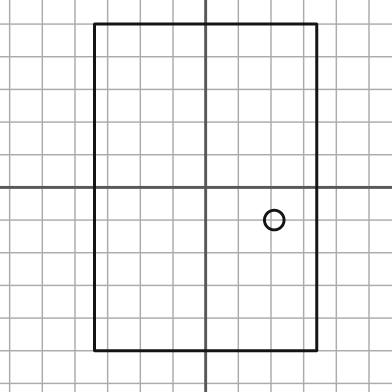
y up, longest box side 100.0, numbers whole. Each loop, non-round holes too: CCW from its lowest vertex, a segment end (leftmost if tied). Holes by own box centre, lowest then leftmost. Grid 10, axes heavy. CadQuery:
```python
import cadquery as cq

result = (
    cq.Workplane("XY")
    .moveTo(-34.0, -50.0)
    .lineTo(34.0, -50.0)
    .lineTo(34.0, 50.0)
    .lineTo(-34.0, 50.0)
    .close()
    .moveTo(21.0, -10.0)
    .circle(3.0)
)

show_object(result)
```